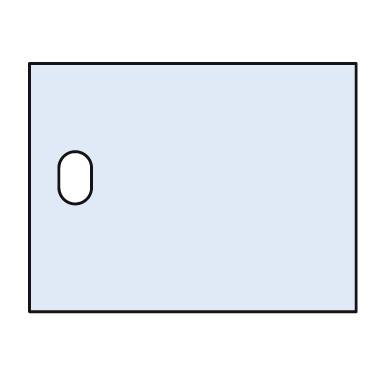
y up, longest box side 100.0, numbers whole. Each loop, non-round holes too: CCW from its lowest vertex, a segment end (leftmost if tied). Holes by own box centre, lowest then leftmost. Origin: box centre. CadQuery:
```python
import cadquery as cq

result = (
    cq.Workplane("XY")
    .moveTo(-50.0, -38.0)
    .lineTo(50.0, -38.0)
    .lineTo(50.0, 38.0)
    .lineTo(-50.0, 38.0)
    .close()
    .moveTo(-41.0, 0.0)
    .threePointArc((-36.0, -5.0), (-31.0, 0.0))
    .lineTo(-31.0, 6.0)
    .threePointArc((-36.0, 11.0), (-41.0, 6.0))
    .close()
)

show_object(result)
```